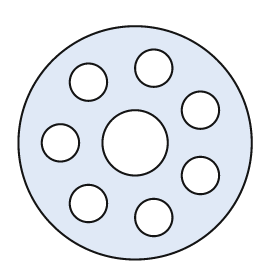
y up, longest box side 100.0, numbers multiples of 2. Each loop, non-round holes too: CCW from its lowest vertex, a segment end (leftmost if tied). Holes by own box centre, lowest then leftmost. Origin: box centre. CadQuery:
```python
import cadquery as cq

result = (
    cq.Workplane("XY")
    .moveTo(0.0, 0.0)
    .circle(50.0)
    .moveTo(8.0, -32.0)
    .circle(8.0)
    .moveTo(-20.0, -26.0)
    .circle(8.0)
    .moveTo(28.0, -14.0)
    .circle(8.0)
    .moveTo(-32.0, 0.0)
    .circle(8.0)
    .moveTo(0.0, 0.0)
    .circle(14.0)
    .moveTo(28.0, 14.0)
    .circle(8.0)
    .moveTo(-20.0, 26.0)
    .circle(8.0)
    .moveTo(8.0, 32.0)
    .circle(8.0)
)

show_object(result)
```